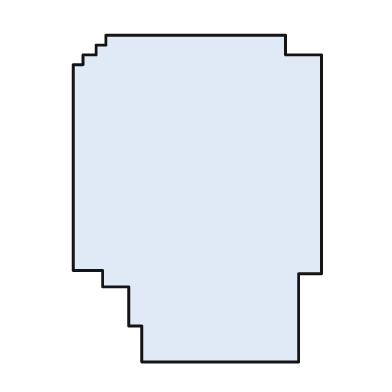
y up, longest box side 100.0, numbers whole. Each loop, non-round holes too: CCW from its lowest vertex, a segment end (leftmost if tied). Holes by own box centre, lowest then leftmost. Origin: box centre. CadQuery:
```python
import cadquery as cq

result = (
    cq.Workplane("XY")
    .moveTo(-17.0, -50.0)
    .lineTo(31.0, -50.0)
    .lineTo(31.0, -23.0)
    .lineTo(38.0, -23.0)
    .lineTo(38.0, 44.0)
    .lineTo(27.0, 44.0)
    .lineTo(27.0, 50.0)
    .lineTo(-28.0, 50.0)
    .lineTo(-28.0, 47.0)
    .lineTo(-31.0, 47.0)
    .lineTo(-31.0, 44.0)
    .lineTo(-35.0, 44.0)
    .lineTo(-35.0, 41.0)
    .lineTo(-38.0, 41.0)
    .lineTo(-38.0, -22.0)
    .lineTo(-29.0, -22.0)
    .lineTo(-29.0, -27.0)
    .lineTo(-21.0, -27.0)
    .lineTo(-21.0, -39.0)
    .lineTo(-17.0, -39.0)
    .close()
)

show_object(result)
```